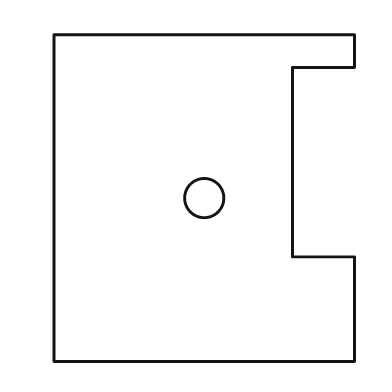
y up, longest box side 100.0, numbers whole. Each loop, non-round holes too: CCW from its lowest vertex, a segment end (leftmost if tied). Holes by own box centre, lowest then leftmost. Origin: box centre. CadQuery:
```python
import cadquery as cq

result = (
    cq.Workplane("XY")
    .moveTo(-46.0, -50.0)
    .lineTo(46.0, -50.0)
    .lineTo(46.0, -18.0)
    .lineTo(27.0, -18.0)
    .lineTo(27.0, 40.0)
    .lineTo(46.0, 40.0)
    .lineTo(46.0, 50.0)
    .lineTo(-46.0, 50.0)
    .close()
    .moveTo(0.0, 0.0)
    .circle(6.0)
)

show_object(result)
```